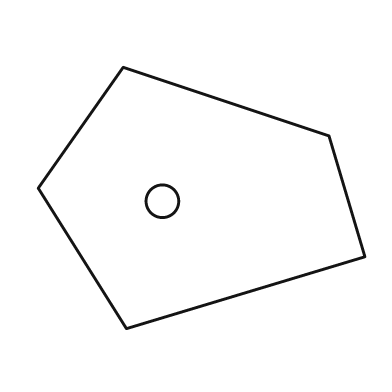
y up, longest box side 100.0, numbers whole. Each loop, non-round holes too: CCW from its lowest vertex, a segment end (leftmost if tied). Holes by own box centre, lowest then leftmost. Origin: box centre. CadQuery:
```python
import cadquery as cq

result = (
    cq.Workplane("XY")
    .moveTo(-23.0, -40.0)
    .lineTo(50.0, -18.0)
    .lineTo(39.0, 19.0)
    .lineTo(-24.0, 40.0)
    .lineTo(-50.0, 3.0)
    .close()
    .moveTo(-12.0, -1.0)
    .circle(5.0)
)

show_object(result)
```